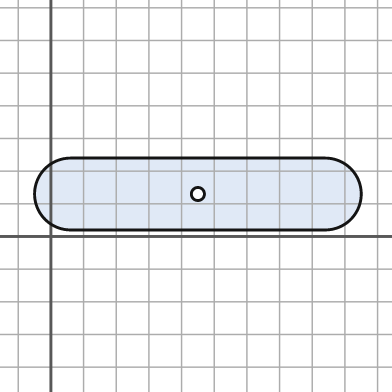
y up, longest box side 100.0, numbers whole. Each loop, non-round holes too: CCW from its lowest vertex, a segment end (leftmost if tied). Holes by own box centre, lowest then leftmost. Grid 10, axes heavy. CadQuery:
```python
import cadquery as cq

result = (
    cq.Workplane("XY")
    .moveTo(6.0, 2.0)
    .lineTo(84.0, 2.0)
    .threePointArc((95.0, 13.0), (84.0, 24.0))
    .lineTo(6.0, 24.0)
    .threePointArc((-5.0, 13.0), (6.0, 2.0))
    .close()
    .moveTo(45.0, 13.0)
    .circle(2.0)
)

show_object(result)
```